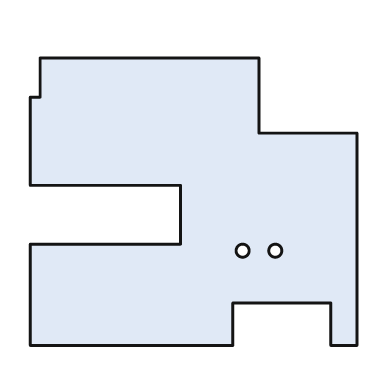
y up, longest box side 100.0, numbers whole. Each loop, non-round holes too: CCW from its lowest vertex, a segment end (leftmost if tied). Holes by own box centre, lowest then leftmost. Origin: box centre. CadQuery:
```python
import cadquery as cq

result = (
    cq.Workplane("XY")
    .moveTo(-50.0, -44.0)
    .lineTo(12.0, -44.0)
    .lineTo(12.0, -31.0)
    .lineTo(42.0, -31.0)
    .lineTo(42.0, -44.0)
    .lineTo(50.0, -44.0)
    .lineTo(50.0, 21.0)
    .lineTo(20.0, 21.0)
    .lineTo(20.0, 44.0)
    .lineTo(-47.0, 44.0)
    .lineTo(-47.0, 32.0)
    .lineTo(-50.0, 32.0)
    .lineTo(-50.0, 5.0)
    .lineTo(-4.0, 5.0)
    .lineTo(-4.0, -13.0)
    .lineTo(-50.0, -13.0)
    .close()
    .moveTo(15.0, -15.0)
    .circle(2.0)
    .moveTo(25.0, -15.0)
    .circle(2.0)
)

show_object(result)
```